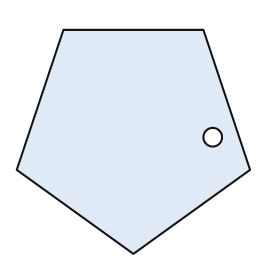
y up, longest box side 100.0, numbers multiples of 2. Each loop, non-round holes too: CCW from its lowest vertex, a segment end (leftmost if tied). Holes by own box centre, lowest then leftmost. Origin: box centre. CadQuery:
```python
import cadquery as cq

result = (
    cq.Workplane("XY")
    .moveTo(0.0, -48.0)
    .lineTo(50.0, -12.0)
    .lineTo(30.0, 48.0)
    .lineTo(-30.0, 48.0)
    .lineTo(-50.0, -12.0)
    .close()
    .moveTo(34.0, 2.0)
    .circle(4.0)
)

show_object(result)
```